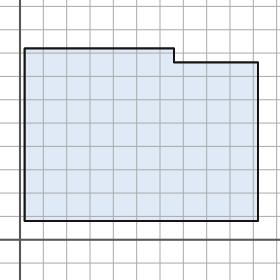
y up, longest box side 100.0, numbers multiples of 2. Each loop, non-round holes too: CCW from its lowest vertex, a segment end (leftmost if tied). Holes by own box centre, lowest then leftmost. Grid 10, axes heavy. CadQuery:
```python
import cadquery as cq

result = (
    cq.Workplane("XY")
    .moveTo(2.0, 8.0)
    .lineTo(102.0, 8.0)
    .lineTo(102.0, 76.0)
    .lineTo(66.0, 76.0)
    .lineTo(66.0, 82.0)
    .lineTo(2.0, 82.0)
    .close()
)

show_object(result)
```